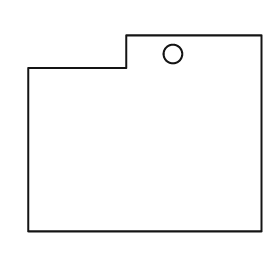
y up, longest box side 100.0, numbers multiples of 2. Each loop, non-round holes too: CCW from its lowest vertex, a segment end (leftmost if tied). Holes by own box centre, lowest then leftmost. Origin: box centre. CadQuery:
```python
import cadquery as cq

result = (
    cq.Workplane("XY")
    .moveTo(-50.0, -42.0)
    .lineTo(50.0, -42.0)
    .lineTo(50.0, 42.0)
    .lineTo(-8.0, 42.0)
    .lineTo(-8.0, 28.0)
    .lineTo(-50.0, 28.0)
    .close()
    .moveTo(12.0, 34.0)
    .circle(4.0)
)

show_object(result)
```